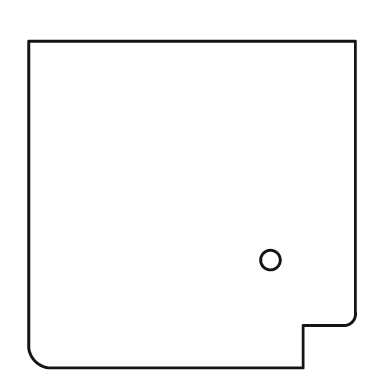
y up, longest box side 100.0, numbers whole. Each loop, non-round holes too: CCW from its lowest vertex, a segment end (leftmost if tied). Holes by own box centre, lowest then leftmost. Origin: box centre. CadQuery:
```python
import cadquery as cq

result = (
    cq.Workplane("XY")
    .moveTo(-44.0, -50.0)
    .lineTo(34.0, -50.0)
    .lineTo(34.0, -37.0)
    .lineTo(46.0, -37.0)
    .threePointArc((49.0, -36.0), (50.0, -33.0))
    .lineTo(50.0, 50.0)
    .lineTo(-50.0, 50.0)
    .lineTo(-50.0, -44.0)
    .threePointArc((-48.0, -48.0), (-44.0, -50.0))
    .close()
    .moveTo(24.0, -17.0)
    .circle(3.0)
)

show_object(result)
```